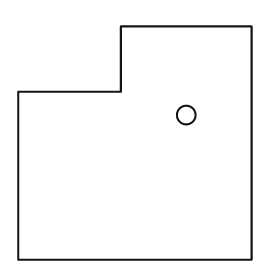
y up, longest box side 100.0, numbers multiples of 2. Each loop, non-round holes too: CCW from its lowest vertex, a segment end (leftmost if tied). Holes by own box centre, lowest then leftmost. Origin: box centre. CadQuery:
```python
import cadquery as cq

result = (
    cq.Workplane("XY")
    .moveTo(-50.0, -50.0)
    .lineTo(50.0, -50.0)
    .lineTo(50.0, 50.0)
    .lineTo(-6.0, 50.0)
    .lineTo(-6.0, 22.0)
    .lineTo(-50.0, 22.0)
    .close()
    .moveTo(22.0, 12.0)
    .circle(4.0)
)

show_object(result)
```